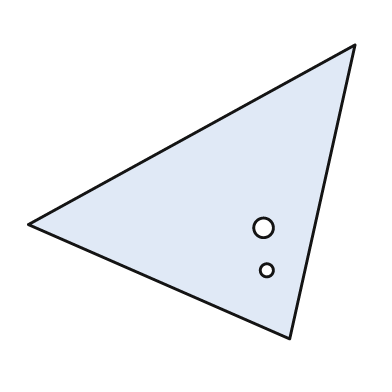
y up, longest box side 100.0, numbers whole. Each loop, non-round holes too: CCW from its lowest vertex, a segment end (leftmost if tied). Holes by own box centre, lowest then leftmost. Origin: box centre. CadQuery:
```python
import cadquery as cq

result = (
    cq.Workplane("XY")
    .moveTo(30.0, -45.0)
    .lineTo(50.0, 45.0)
    .lineTo(-50.0, -10.0)
    .close()
    .moveTo(23.0, -24.0)
    .circle(2.0)
    .moveTo(22.0, -11.0)
    .circle(3.0)
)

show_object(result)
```